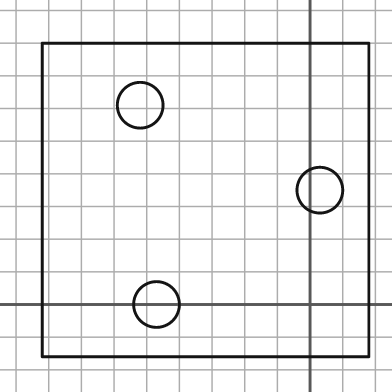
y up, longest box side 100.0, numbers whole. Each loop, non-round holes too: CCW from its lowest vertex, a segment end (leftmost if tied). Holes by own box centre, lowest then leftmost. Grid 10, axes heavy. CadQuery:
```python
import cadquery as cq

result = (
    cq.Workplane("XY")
    .moveTo(-82.0, -16.0)
    .lineTo(18.0, -16.0)
    .lineTo(18.0, 80.0)
    .lineTo(-82.0, 80.0)
    .close()
    .moveTo(-47.0, 0.0)
    .circle(7.0)
    .moveTo(3.0, 35.0)
    .circle(7.0)
    .moveTo(-52.0, 61.0)
    .circle(7.0)
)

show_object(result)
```